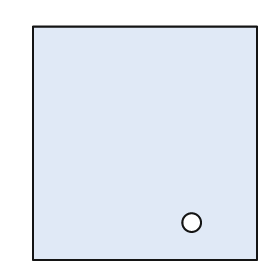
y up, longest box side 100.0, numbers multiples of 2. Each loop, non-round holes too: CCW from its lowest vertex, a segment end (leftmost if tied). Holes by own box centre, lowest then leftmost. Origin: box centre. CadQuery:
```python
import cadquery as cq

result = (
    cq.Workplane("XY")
    .moveTo(-48.0, -50.0)
    .lineTo(48.0, -50.0)
    .lineTo(48.0, 50.0)
    .lineTo(-48.0, 50.0)
    .close()
    .moveTo(20.0, -34.0)
    .circle(4.0)
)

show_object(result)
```